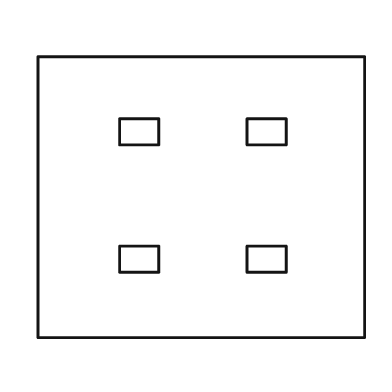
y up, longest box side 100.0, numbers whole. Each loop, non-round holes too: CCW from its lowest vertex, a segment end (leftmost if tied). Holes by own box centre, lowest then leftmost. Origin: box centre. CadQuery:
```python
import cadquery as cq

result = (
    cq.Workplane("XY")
    .moveTo(-50.0, -43.0)
    .lineTo(50.0, -43.0)
    .lineTo(50.0, 43.0)
    .lineTo(-50.0, 43.0)
    .close()
    .moveTo(-25.0, -23.0)
    .lineTo(-13.0, -23.0)
    .lineTo(-13.0, -15.0)
    .lineTo(-25.0, -15.0)
    .close()
    .moveTo(14.0, -23.0)
    .lineTo(26.0, -23.0)
    .lineTo(26.0, -15.0)
    .lineTo(14.0, -15.0)
    .close()
    .moveTo(-25.0, 16.0)
    .lineTo(-13.0, 16.0)
    .lineTo(-13.0, 24.0)
    .lineTo(-25.0, 24.0)
    .close()
    .moveTo(14.0, 16.0)
    .lineTo(26.0, 16.0)
    .lineTo(26.0, 24.0)
    .lineTo(14.0, 24.0)
    .close()
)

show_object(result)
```